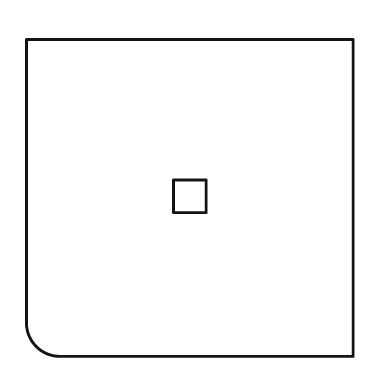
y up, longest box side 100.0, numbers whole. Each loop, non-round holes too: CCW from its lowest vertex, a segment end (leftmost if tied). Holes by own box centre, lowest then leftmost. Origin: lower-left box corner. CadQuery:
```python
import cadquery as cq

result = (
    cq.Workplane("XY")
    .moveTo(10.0, 0.0)
    .lineTo(100.0, 0.0)
    .lineTo(100.0, 97.0)
    .lineTo(0.0, 97.0)
    .lineTo(0.0, 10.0)
    .threePointArc((3.0, 3.0), (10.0, 0.0))
    .close()
    .moveTo(45.0, 44.0)
    .lineTo(55.0, 44.0)
    .lineTo(55.0, 54.0)
    .lineTo(45.0, 54.0)
    .close()
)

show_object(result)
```